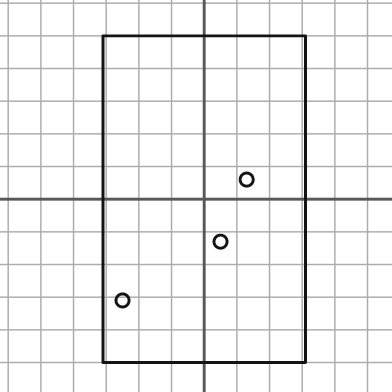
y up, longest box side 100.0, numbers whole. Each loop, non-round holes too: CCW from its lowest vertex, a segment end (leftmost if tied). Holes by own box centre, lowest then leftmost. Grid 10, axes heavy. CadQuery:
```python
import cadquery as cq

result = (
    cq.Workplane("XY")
    .moveTo(-31.0, -50.0)
    .lineTo(31.0, -50.0)
    .lineTo(31.0, 50.0)
    .lineTo(-31.0, 50.0)
    .close()
    .moveTo(-25.0, -31.0)
    .circle(2.0)
    .moveTo(5.0, -13.0)
    .circle(2.0)
    .moveTo(13.0, 6.0)
    .circle(2.0)
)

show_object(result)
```